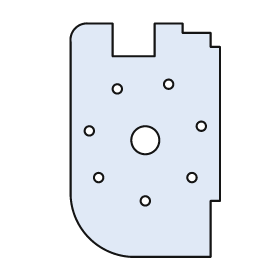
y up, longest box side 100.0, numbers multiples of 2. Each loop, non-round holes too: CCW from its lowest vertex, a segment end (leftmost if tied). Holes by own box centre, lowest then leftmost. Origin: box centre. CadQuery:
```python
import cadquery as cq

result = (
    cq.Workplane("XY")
    .moveTo(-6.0, -50.0)
    .lineTo(28.0, -50.0)
    .lineTo(28.0, -26.0)
    .lineTo(32.0, -26.0)
    .lineTo(32.0, 40.0)
    .lineTo(28.0, 40.0)
    .lineTo(28.0, 46.0)
    .lineTo(16.0, 46.0)
    .lineTo(16.0, 50.0)
    .lineTo(4.0, 50.0)
    .lineTo(4.0, 36.0)
    .lineTo(-14.0, 36.0)
    .lineTo(-14.0, 50.0)
    .lineTo(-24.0, 50.0)
    .threePointArc((-30.0, 48.0), (-32.0, 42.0))
    .lineTo(-32.0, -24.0)
    .threePointArc((-24.0, -42.0), (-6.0, -50.0))
    .close()
    .moveTo(0.0, -26.0)
    .circle(2.0)
    .moveTo(-20.0, -16.0)
    .circle(2.0)
    .moveTo(20.0, -16.0)
    .circle(2.0)
    .moveTo(0.0, 0.0)
    .circle(6.0)
    .moveTo(-24.0, 4.0)
    .circle(2.0)
    .moveTo(24.0, 6.0)
    .circle(2.0)
    .moveTo(-12.0, 22.0)
    .circle(2.0)
    .moveTo(10.0, 24.0)
    .circle(2.0)
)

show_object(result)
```